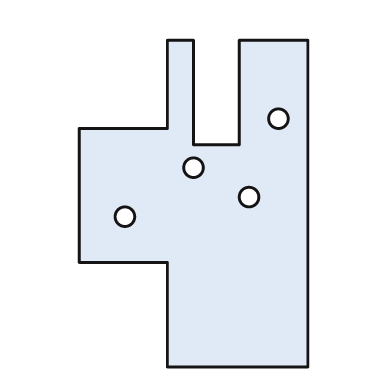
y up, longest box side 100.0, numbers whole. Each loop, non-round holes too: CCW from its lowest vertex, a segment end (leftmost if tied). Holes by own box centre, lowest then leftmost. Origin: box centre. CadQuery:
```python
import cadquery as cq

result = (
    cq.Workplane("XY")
    .moveTo(-8.0, -50.0)
    .lineTo(35.0, -50.0)
    .lineTo(35.0, 50.0)
    .lineTo(14.0, 50.0)
    .lineTo(14.0, 18.0)
    .lineTo(0.0, 18.0)
    .lineTo(0.0, 50.0)
    .lineTo(-8.0, 50.0)
    .lineTo(-8.0, 23.0)
    .lineTo(-35.0, 23.0)
    .lineTo(-35.0, -18.0)
    .lineTo(-8.0, -18.0)
    .close()
    .moveTo(-21.0, -4.0)
    .circle(3.0)
    .moveTo(17.0, 2.0)
    .circle(3.0)
    .moveTo(0.0, 11.0)
    .circle(3.0)
    .moveTo(26.0, 26.0)
    .circle(3.0)
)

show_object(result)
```